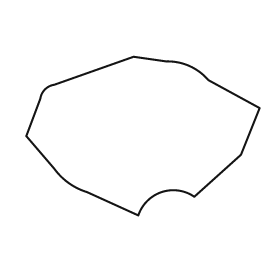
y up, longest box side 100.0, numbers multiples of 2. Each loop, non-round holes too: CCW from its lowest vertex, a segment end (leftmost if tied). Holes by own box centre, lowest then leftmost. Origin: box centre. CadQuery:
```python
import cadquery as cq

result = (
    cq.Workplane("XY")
    .moveTo(-2.0, -34.0)
    .threePointArc((8.0, -24.0), (22.0, -26.0))
    .lineTo(42.0, -8.0)
    .lineTo(50.0, 12.0)
    .lineTo(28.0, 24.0)
    .threePointArc((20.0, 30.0), (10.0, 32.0))
    .lineTo(-4.0, 34.0)
    .lineTo(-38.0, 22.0)
    .threePointArc((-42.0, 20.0), (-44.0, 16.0))
    .lineTo(-50.0, 0.0)
    .lineTo(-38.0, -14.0)
    .threePointArc((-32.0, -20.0), (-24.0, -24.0))
    .close()
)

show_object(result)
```